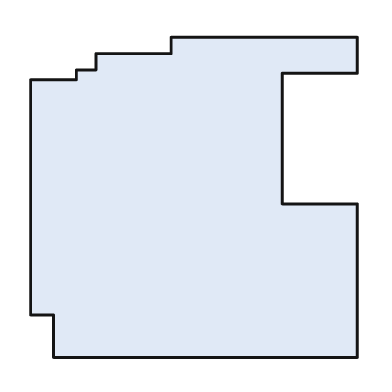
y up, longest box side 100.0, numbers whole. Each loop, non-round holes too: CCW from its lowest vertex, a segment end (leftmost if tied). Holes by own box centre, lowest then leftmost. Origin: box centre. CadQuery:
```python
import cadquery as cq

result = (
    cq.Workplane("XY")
    .moveTo(-43.0, -49.0)
    .lineTo(50.0, -49.0)
    .lineTo(50.0, -2.0)
    .lineTo(27.0, -2.0)
    .lineTo(27.0, 38.0)
    .lineTo(50.0, 38.0)
    .lineTo(50.0, 49.0)
    .lineTo(-7.0, 49.0)
    .lineTo(-7.0, 44.0)
    .lineTo(-30.0, 44.0)
    .lineTo(-30.0, 39.0)
    .lineTo(-36.0, 39.0)
    .lineTo(-36.0, 36.0)
    .lineTo(-50.0, 36.0)
    .lineTo(-50.0, -36.0)
    .lineTo(-43.0, -36.0)
    .close()
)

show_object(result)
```